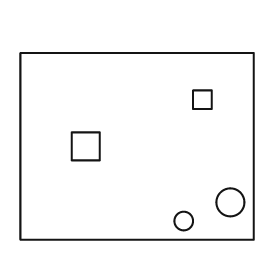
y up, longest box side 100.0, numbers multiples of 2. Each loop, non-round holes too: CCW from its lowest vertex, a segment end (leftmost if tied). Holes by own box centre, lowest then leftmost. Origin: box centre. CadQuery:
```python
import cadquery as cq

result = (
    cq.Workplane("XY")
    .moveTo(-50.0, -40.0)
    .lineTo(50.0, -40.0)
    .lineTo(50.0, 40.0)
    .lineTo(-50.0, 40.0)
    .close()
    .moveTo(20.0, -32.0)
    .circle(4.0)
    .moveTo(40.0, -24.0)
    .circle(6.0)
    .moveTo(-28.0, -6.0)
    .lineTo(-16.0, -6.0)
    .lineTo(-16.0, 6.0)
    .lineTo(-28.0, 6.0)
    .close()
    .moveTo(24.0, 16.0)
    .lineTo(32.0, 16.0)
    .lineTo(32.0, 24.0)
    .lineTo(24.0, 24.0)
    .close()
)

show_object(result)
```